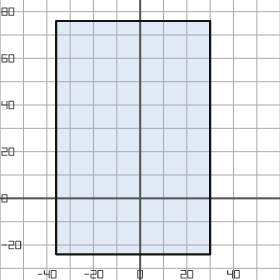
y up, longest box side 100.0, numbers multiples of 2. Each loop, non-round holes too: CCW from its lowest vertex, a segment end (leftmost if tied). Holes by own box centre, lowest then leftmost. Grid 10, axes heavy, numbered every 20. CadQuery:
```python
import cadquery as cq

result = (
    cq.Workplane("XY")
    .moveTo(-36.0, -24.0)
    .lineTo(30.0, -24.0)
    .lineTo(30.0, 76.0)
    .lineTo(-36.0, 76.0)
    .close()
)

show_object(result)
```